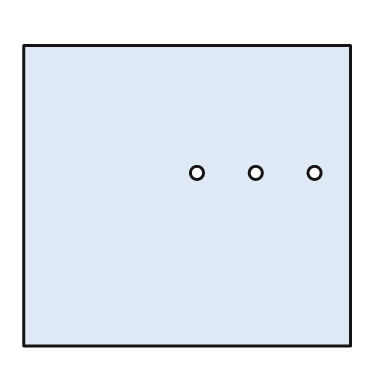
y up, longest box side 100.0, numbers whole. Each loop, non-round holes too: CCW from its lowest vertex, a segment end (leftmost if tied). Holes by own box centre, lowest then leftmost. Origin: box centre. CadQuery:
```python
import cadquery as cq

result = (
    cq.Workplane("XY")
    .moveTo(-50.0, -46.0)
    .lineTo(50.0, -46.0)
    .lineTo(50.0, 46.0)
    .lineTo(-50.0, 46.0)
    .close()
    .moveTo(3.0, 7.0)
    .circle(2.0)
    .moveTo(21.0, 7.0)
    .circle(2.0)
    .moveTo(39.0, 7.0)
    .circle(2.0)
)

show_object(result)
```